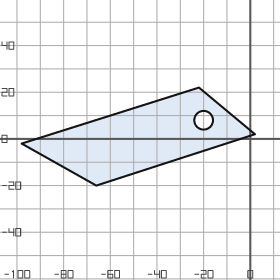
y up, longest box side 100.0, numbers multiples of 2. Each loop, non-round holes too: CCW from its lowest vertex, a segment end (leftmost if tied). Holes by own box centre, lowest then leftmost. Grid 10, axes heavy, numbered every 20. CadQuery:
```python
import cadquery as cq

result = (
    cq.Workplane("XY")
    .moveTo(-66.0, -20.0)
    .lineTo(2.0, 2.0)
    .lineTo(-22.0, 22.0)
    .lineTo(-98.0, -2.0)
    .close()
    .moveTo(-20.0, 8.0)
    .circle(4.0)
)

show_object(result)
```